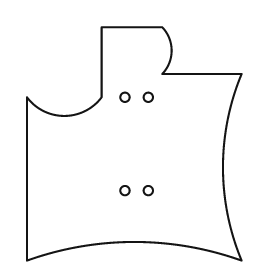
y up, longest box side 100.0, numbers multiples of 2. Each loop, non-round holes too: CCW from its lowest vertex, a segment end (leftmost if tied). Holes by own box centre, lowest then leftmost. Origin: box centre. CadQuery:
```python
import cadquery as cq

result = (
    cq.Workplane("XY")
    .moveTo(-46.0, -50.0)
    .threePointArc((0.0, -42.0), (46.0, -50.0))
    .threePointArc((38.0, -10.0), (46.0, 30.0))
    .lineTo(12.0, 30.0)
    .threePointArc((16.0, 40.0), (12.0, 50.0))
    .lineTo(-14.0, 50.0)
    .lineTo(-14.0, 20.0)
    .threePointArc((-30.0, 12.0), (-46.0, 20.0))
    .close()
    .moveTo(-4.0, -20.0)
    .circle(2.0)
    .moveTo(6.0, -20.0)
    .circle(2.0)
    .moveTo(-4.0, 20.0)
    .circle(2.0)
    .moveTo(6.0, 20.0)
    .circle(2.0)
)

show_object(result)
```